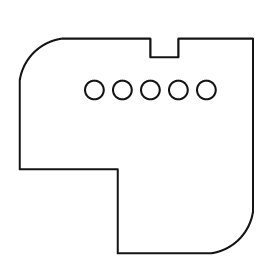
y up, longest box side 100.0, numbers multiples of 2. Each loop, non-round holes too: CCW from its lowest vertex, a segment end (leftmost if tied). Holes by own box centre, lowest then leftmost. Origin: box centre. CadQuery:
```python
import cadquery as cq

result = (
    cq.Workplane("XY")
    .moveTo(-8.0, -46.0)
    .lineTo(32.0, -46.0)
    .threePointArc((44.0, -40.0), (50.0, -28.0))
    .lineTo(50.0, 46.0)
    .lineTo(18.0, 46.0)
    .lineTo(18.0, 38.0)
    .lineTo(6.0, 38.0)
    .lineTo(6.0, 46.0)
    .lineTo(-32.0, 46.0)
    .threePointArc((-44.0, 40.0), (-50.0, 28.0))
    .lineTo(-50.0, -10.0)
    .lineTo(-8.0, -10.0)
    .close()
    .moveTo(-18.0, 24.0)
    .circle(4.0)
    .moveTo(-6.0, 24.0)
    .circle(4.0)
    .moveTo(6.0, 24.0)
    .circle(4.0)
    .moveTo(18.0, 24.0)
    .circle(4.0)
    .moveTo(30.0, 24.0)
    .circle(4.0)
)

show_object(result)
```